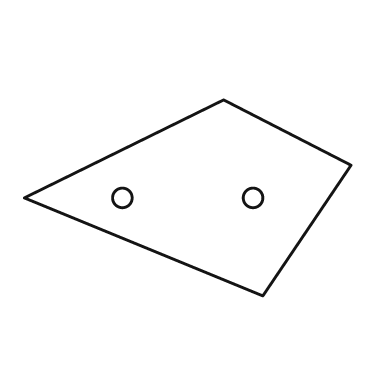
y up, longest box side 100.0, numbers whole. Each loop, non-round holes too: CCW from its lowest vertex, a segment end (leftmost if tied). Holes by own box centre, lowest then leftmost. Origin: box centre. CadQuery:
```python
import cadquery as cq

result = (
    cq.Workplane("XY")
    .moveTo(23.0, -30.0)
    .lineTo(50.0, 10.0)
    .lineTo(11.0, 30.0)
    .lineTo(-50.0, 0.0)
    .close()
    .moveTo(-20.0, 0.0)
    .circle(3.0)
    .moveTo(20.0, 0.0)
    .circle(3.0)
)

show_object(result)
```